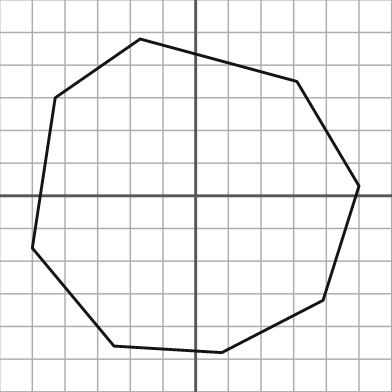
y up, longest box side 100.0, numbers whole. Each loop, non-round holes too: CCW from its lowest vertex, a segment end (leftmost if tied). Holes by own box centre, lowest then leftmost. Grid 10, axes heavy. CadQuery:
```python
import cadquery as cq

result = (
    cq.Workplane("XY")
    .moveTo(8.0, -48.0)
    .lineTo(39.0, -32.0)
    .lineTo(50.0, 3.0)
    .lineTo(31.0, 35.0)
    .lineTo(-17.0, 48.0)
    .lineTo(-43.0, 30.0)
    .lineTo(-50.0, -16.0)
    .lineTo(-25.0, -46.0)
    .close()
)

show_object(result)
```